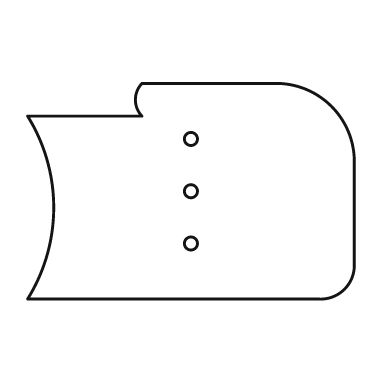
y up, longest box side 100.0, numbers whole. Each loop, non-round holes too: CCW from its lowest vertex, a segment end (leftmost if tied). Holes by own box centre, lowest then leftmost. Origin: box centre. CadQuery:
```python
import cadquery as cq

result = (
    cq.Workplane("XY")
    .moveTo(-50.0, -33.0)
    .lineTo(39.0, -33.0)
    .threePointArc((47.0, -30.0), (50.0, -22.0))
    .lineTo(50.0, 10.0)
    .threePointArc((43.0, 26.0), (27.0, 33.0))
    .lineTo(-15.0, 33.0)
    .threePointArc((-17.0, 28.0), (-15.0, 23.0))
    .lineTo(-50.0, 23.0)
    .threePointArc((-42.0, -5.0), (-50.0, -33.0))
    .close()
    .moveTo(0.0, -16.0)
    .circle(2.0)
    .moveTo(0.0, 0.0)
    .circle(2.0)
    .moveTo(0.0, 16.0)
    .circle(2.0)
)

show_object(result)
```